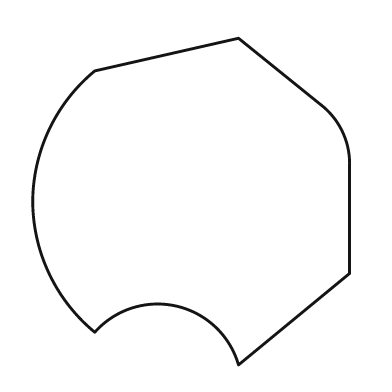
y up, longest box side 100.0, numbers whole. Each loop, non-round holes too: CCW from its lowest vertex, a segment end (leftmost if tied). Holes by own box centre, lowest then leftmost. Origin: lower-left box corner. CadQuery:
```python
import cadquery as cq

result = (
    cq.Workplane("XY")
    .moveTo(63.0, 0.0)
    .lineTo(97.0, 28.0)
    .lineTo(97.0, 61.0)
    .threePointArc((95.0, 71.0), (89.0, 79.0))
    .lineTo(63.0, 100.0)
    .lineTo(19.0, 90.0)
    .threePointArc((5.0, 72.0), (0.0, 50.0))
    .threePointArc((5.0, 28.0), (19.0, 10.0))
    .threePointArc((44.0, 18.0), (63.0, 0.0))
    .close()
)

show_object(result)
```